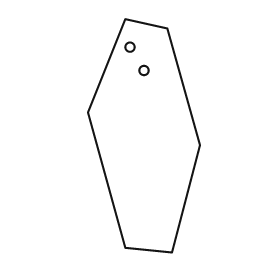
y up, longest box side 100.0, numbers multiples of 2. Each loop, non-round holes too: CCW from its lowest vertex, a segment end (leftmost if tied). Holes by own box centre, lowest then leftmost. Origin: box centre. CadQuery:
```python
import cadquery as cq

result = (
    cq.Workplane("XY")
    .moveTo(12.0, -50.0)
    .lineTo(24.0, -4.0)
    .lineTo(10.0, 46.0)
    .lineTo(-8.0, 50.0)
    .lineTo(-24.0, 10.0)
    .lineTo(-8.0, -48.0)
    .close()
    .moveTo(0.0, 28.0)
    .circle(2.0)
    .moveTo(-6.0, 38.0)
    .circle(2.0)
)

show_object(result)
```